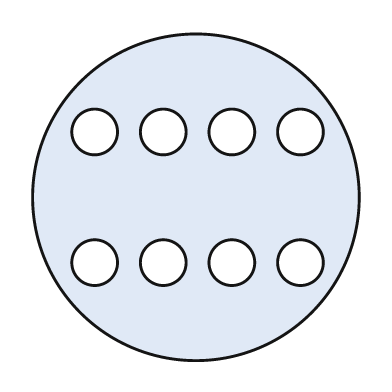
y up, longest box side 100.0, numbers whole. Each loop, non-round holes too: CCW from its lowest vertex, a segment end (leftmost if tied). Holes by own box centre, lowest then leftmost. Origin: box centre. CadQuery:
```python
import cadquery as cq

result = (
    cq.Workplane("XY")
    .moveTo(0.0, 0.0)
    .circle(50.0)
    .moveTo(-31.0, -20.0)
    .circle(7.0)
    .moveTo(-10.0, -20.0)
    .circle(7.0)
    .moveTo(11.0, -20.0)
    .circle(7.0)
    .moveTo(32.0, -20.0)
    .circle(7.0)
    .moveTo(-31.0, 20.0)
    .circle(7.0)
    .moveTo(-10.0, 20.0)
    .circle(7.0)
    .moveTo(11.0, 20.0)
    .circle(7.0)
    .moveTo(32.0, 20.0)
    .circle(7.0)
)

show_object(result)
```